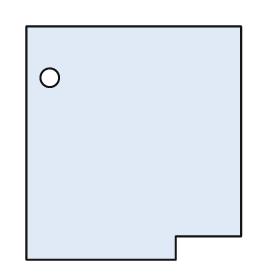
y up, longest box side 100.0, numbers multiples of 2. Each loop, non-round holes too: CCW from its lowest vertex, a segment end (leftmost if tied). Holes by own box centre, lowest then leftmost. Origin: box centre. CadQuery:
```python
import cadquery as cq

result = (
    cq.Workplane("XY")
    .moveTo(-46.0, -50.0)
    .lineTo(18.0, -50.0)
    .lineTo(18.0, -40.0)
    .lineTo(46.0, -40.0)
    .lineTo(46.0, 50.0)
    .lineTo(-46.0, 50.0)
    .close()
    .moveTo(-36.0, 28.0)
    .circle(4.0)
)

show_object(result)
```